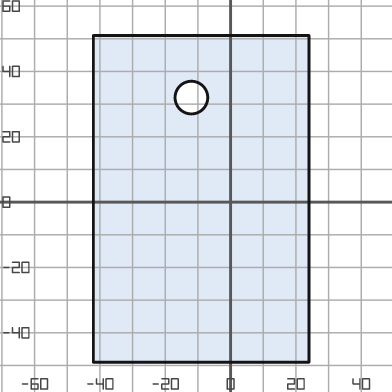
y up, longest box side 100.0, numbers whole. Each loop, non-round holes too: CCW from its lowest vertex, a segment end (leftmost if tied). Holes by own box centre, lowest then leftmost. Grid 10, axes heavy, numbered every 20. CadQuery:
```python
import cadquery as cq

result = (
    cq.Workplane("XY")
    .moveTo(-42.0, -49.0)
    .lineTo(24.0, -49.0)
    .lineTo(24.0, 51.0)
    .lineTo(-42.0, 51.0)
    .close()
    .moveTo(-12.0, 32.0)
    .circle(5.0)
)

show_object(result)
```